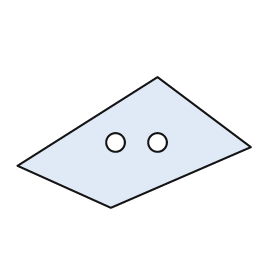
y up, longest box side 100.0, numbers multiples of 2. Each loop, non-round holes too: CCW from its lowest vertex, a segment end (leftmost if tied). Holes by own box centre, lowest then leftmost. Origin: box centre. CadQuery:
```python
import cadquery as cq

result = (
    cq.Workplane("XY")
    .moveTo(-10.0, -28.0)
    .lineTo(50.0, -2.0)
    .lineTo(10.0, 28.0)
    .lineTo(-50.0, -10.0)
    .close()
    .moveTo(-8.0, 0.0)
    .circle(4.0)
    .moveTo(10.0, 0.0)
    .circle(4.0)
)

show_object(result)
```